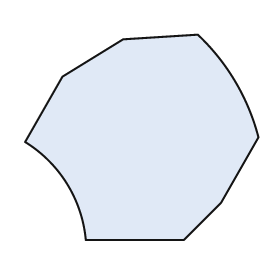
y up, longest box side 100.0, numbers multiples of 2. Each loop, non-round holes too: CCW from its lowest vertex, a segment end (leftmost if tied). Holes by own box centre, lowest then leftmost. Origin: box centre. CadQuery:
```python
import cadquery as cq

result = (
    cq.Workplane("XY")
    .moveTo(-24.0, -44.0)
    .lineTo(18.0, -44.0)
    .lineTo(34.0, -28.0)
    .lineTo(50.0, 0.0)
    .threePointArc((40.0, 24.0), (24.0, 44.0))
    .lineTo(-8.0, 42.0)
    .lineTo(-34.0, 26.0)
    .lineTo(-50.0, -2.0)
    .threePointArc((-32.0, -20.0), (-24.0, -44.0))
    .close()
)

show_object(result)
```